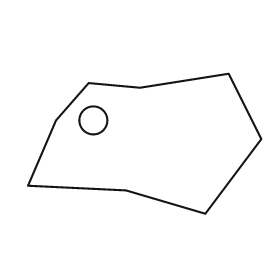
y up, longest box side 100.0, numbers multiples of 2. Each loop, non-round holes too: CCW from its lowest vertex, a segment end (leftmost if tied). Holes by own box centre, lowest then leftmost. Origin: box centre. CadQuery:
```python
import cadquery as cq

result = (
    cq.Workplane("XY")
    .moveTo(26.0, -30.0)
    .lineTo(50.0, 2.0)
    .lineTo(36.0, 30.0)
    .lineTo(-2.0, 24.0)
    .lineTo(-24.0, 26.0)
    .lineTo(-38.0, 10.0)
    .lineTo(-50.0, -18.0)
    .lineTo(-8.0, -20.0)
    .close()
    .moveTo(-22.0, 10.0)
    .circle(6.0)
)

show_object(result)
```